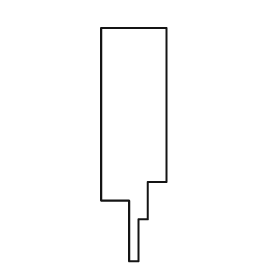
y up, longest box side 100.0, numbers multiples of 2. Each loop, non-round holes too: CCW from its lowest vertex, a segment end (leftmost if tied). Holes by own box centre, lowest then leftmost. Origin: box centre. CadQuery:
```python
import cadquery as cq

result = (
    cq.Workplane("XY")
    .moveTo(-2.0, -50.0)
    .lineTo(2.0, -50.0)
    .lineTo(2.0, -32.0)
    .lineTo(6.0, -32.0)
    .lineTo(6.0, -16.0)
    .lineTo(14.0, -16.0)
    .lineTo(14.0, 50.0)
    .lineTo(-14.0, 50.0)
    .lineTo(-14.0, -24.0)
    .lineTo(-2.0, -24.0)
    .close()
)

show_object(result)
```